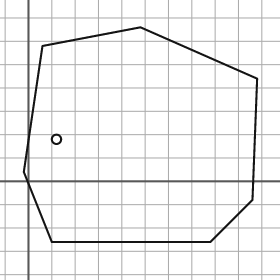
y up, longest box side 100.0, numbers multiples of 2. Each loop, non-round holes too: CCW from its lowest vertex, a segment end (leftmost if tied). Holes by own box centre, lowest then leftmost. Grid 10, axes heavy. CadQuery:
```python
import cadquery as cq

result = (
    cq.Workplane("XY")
    .moveTo(10.0, -26.0)
    .lineTo(78.0, -26.0)
    .lineTo(96.0, -8.0)
    .lineTo(98.0, 44.0)
    .lineTo(48.0, 66.0)
    .lineTo(6.0, 58.0)
    .lineTo(-2.0, 4.0)
    .close()
    .moveTo(12.0, 18.0)
    .circle(2.0)
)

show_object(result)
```